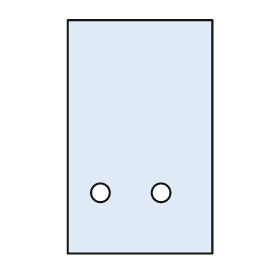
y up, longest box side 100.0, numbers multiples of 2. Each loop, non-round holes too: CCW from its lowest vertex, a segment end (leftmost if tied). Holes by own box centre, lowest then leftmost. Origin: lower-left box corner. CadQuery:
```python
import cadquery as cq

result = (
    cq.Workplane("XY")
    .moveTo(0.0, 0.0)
    .lineTo(62.0, 0.0)
    .lineTo(62.0, 100.0)
    .lineTo(0.0, 100.0)
    .close()
    .moveTo(14.0, 26.0)
    .circle(4.0)
    .moveTo(40.0, 26.0)
    .circle(4.0)
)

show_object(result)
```